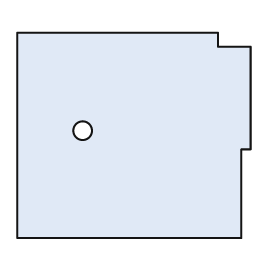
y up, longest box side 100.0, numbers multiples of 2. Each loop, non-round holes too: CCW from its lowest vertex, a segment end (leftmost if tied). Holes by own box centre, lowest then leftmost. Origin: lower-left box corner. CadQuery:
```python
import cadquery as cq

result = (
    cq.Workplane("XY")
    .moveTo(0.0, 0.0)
    .lineTo(96.0, 0.0)
    .lineTo(96.0, 38.0)
    .lineTo(100.0, 38.0)
    .lineTo(100.0, 82.0)
    .lineTo(86.0, 82.0)
    .lineTo(86.0, 88.0)
    .lineTo(0.0, 88.0)
    .close()
    .moveTo(28.0, 46.0)
    .circle(4.0)
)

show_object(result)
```